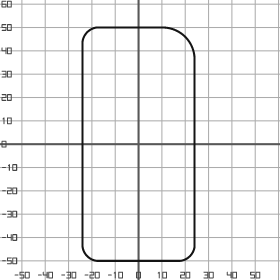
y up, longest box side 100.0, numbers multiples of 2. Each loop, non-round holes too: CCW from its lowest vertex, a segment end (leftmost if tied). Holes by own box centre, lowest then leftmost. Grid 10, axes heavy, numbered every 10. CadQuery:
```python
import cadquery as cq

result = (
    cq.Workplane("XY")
    .moveTo(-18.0, -50.0)
    .lineTo(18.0, -50.0)
    .threePointArc((22.0, -48.0), (24.0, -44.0))
    .lineTo(24.0, 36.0)
    .threePointArc((20.0, 46.0), (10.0, 50.0))
    .lineTo(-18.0, 50.0)
    .threePointArc((-22.0, 48.0), (-24.0, 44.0))
    .lineTo(-24.0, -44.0)
    .threePointArc((-22.0, -48.0), (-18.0, -50.0))
    .close()
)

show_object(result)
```